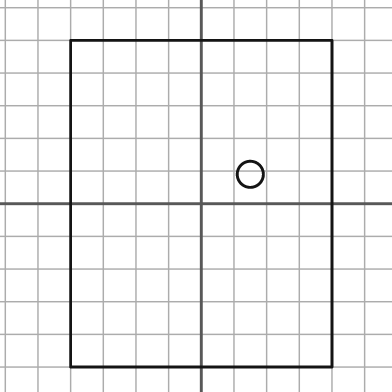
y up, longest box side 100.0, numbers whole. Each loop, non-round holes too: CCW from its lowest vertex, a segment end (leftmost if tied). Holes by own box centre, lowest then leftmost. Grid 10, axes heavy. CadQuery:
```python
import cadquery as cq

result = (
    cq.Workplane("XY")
    .moveTo(-40.0, -50.0)
    .lineTo(40.0, -50.0)
    .lineTo(40.0, 50.0)
    .lineTo(-40.0, 50.0)
    .close()
    .moveTo(15.0, 9.0)
    .circle(4.0)
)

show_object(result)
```